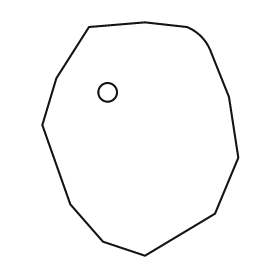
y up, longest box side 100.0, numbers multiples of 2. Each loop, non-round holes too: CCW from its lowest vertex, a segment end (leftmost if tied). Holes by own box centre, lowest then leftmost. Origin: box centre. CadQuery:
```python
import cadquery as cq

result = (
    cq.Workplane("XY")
    .moveTo(2.0, -50.0)
    .lineTo(32.0, -32.0)
    .lineTo(42.0, -8.0)
    .lineTo(38.0, 18.0)
    .lineTo(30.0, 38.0)
    .threePointArc((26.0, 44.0), (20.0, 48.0))
    .lineTo(2.0, 50.0)
    .lineTo(-22.0, 48.0)
    .lineTo(-36.0, 26.0)
    .lineTo(-42.0, 6.0)
    .lineTo(-30.0, -28.0)
    .lineTo(-16.0, -44.0)
    .close()
    .moveTo(-14.0, 20.0)
    .circle(4.0)
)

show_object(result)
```